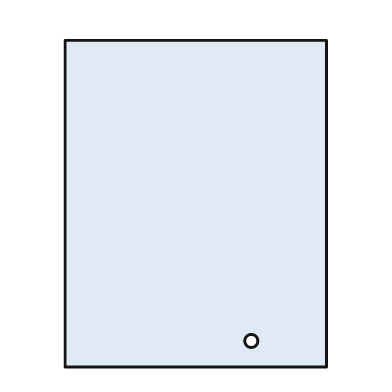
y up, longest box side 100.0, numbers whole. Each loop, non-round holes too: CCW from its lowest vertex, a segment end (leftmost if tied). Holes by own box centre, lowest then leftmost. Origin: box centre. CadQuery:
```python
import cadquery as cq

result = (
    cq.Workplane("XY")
    .moveTo(-40.0, -50.0)
    .lineTo(40.0, -50.0)
    .lineTo(40.0, 50.0)
    .lineTo(-40.0, 50.0)
    .close()
    .moveTo(17.0, -42.0)
    .circle(2.0)
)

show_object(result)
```